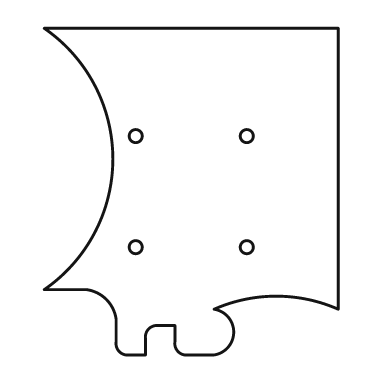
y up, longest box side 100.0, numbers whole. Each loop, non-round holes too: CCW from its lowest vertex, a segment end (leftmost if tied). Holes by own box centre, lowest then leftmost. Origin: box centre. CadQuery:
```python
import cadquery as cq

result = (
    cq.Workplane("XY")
    .moveTo(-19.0, -50.0)
    .lineTo(-14.0, -50.0)
    .lineTo(-14.0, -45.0)
    .threePointArc((-13.0, -42.0), (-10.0, -41.0))
    .lineTo(-5.0, -41.0)
    .lineTo(-5.0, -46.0)
    .threePointArc((-4.0, -49.0), (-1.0, -50.0))
    .lineTo(7.0, -50.0)
    .threePointArc((13.0, -43.0), (7.0, -36.0))
    .threePointArc((26.0, -32.0), (45.0, -36.0))
    .lineTo(45.0, 50.0)
    .lineTo(-45.0, 50.0)
    .threePointArc((-24.0, 10.0), (-45.0, -30.0))
    .lineTo(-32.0, -30.0)
    .threePointArc((-26.0, -33.0), (-23.0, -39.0))
    .lineTo(-23.0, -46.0)
    .threePointArc((-22.0, -49.0), (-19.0, -50.0))
    .close()
    .moveTo(-17.0, -17.0)
    .circle(2.0)
    .moveTo(17.0, -17.0)
    .circle(2.0)
    .moveTo(-17.0, 17.0)
    .circle(2.0)
    .moveTo(17.0, 17.0)
    .circle(2.0)
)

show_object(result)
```